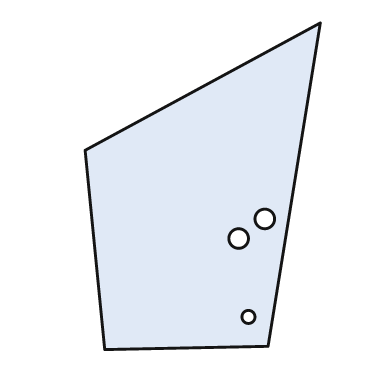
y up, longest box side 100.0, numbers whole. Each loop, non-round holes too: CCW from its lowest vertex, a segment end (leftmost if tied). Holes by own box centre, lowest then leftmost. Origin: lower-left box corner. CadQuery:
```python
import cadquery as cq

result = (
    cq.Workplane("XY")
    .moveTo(6.0, 0.0)
    .lineTo(56.0, 1.0)
    .lineTo(72.0, 100.0)
    .lineTo(0.0, 61.0)
    .close()
    .moveTo(50.0, 10.0)
    .circle(2.0)
    .moveTo(47.0, 34.0)
    .circle(3.0)
    .moveTo(55.0, 40.0)
    .circle(3.0)
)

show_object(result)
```